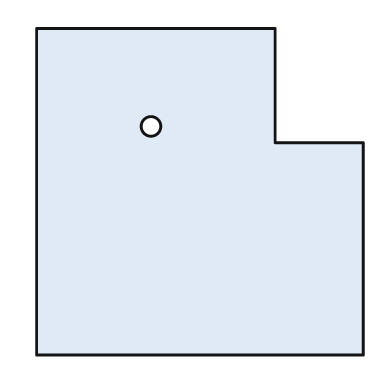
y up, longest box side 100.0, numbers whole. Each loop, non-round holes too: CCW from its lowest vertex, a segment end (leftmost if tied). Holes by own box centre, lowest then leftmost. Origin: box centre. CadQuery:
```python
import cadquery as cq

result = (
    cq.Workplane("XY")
    .moveTo(-50.0, -50.0)
    .lineTo(50.0, -50.0)
    .lineTo(50.0, 15.0)
    .lineTo(23.0, 15.0)
    .lineTo(23.0, 50.0)
    .lineTo(-50.0, 50.0)
    .close()
    .moveTo(-15.0, 20.0)
    .circle(3.0)
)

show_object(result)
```